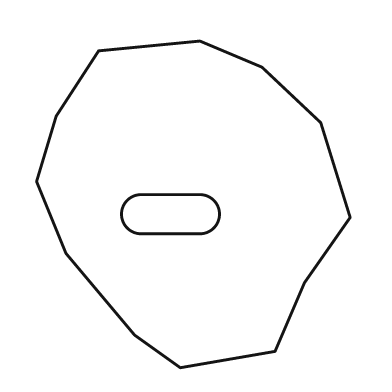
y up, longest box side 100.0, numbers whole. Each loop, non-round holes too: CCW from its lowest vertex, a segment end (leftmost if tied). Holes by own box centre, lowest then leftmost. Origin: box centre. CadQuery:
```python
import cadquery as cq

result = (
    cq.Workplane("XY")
    .moveTo(-4.0, -50.0)
    .lineTo(25.0, -45.0)
    .lineTo(34.0, -24.0)
    .lineTo(48.0, -4.0)
    .lineTo(39.0, 25.0)
    .lineTo(21.0, 42.0)
    .lineTo(2.0, 50.0)
    .lineTo(-29.0, 47.0)
    .lineTo(-42.0, 27.0)
    .lineTo(-48.0, 7.0)
    .lineTo(-39.0, -15.0)
    .lineTo(-18.0, -40.0)
    .close()
    .moveTo(-16.0, -9.0)
    .lineTo(2.0, -9.0)
    .threePointArc((8.0, -3.0), (2.0, 3.0))
    .lineTo(-16.0, 3.0)
    .threePointArc((-22.0, -3.0), (-16.0, -9.0))
    .close()
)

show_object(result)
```